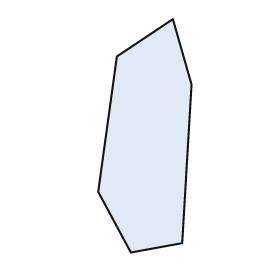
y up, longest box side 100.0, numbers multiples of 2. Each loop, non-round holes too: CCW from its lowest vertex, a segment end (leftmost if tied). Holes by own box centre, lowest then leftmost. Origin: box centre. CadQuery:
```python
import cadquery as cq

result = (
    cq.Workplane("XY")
    .moveTo(-6.0, -50.0)
    .lineTo(16.0, -46.0)
    .lineTo(20.0, 22.0)
    .lineTo(12.0, 50.0)
    .lineTo(-12.0, 34.0)
    .lineTo(-20.0, -24.0)
    .close()
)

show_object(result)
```